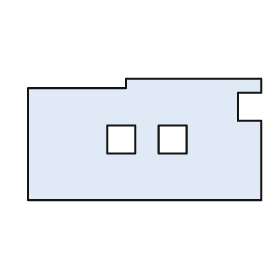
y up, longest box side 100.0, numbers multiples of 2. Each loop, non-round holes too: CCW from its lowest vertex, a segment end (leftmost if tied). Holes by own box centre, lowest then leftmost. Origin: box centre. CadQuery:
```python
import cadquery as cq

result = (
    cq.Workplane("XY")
    .moveTo(-50.0, -26.0)
    .lineTo(50.0, -26.0)
    .lineTo(50.0, 8.0)
    .lineTo(40.0, 8.0)
    .lineTo(40.0, 20.0)
    .lineTo(50.0, 20.0)
    .lineTo(50.0, 26.0)
    .lineTo(-8.0, 26.0)
    .lineTo(-8.0, 22.0)
    .lineTo(-50.0, 22.0)
    .close()
    .moveTo(-16.0, -6.0)
    .lineTo(-4.0, -6.0)
    .lineTo(-4.0, 6.0)
    .lineTo(-16.0, 6.0)
    .close()
    .moveTo(6.0, -6.0)
    .lineTo(18.0, -6.0)
    .lineTo(18.0, 6.0)
    .lineTo(6.0, 6.0)
    .close()
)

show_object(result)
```